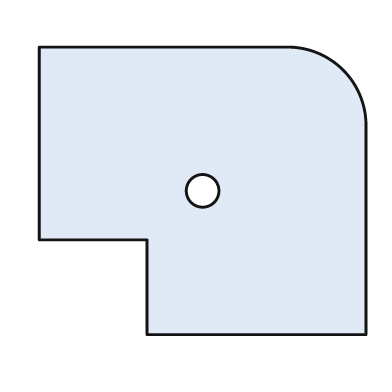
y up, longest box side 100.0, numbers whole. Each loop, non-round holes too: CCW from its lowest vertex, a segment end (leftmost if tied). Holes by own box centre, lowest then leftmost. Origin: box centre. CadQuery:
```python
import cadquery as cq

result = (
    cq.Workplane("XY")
    .moveTo(-17.0, -44.0)
    .lineTo(50.0, -44.0)
    .lineTo(50.0, 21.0)
    .threePointArc((43.0, 37.0), (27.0, 44.0))
    .lineTo(-50.0, 44.0)
    .lineTo(-50.0, -15.0)
    .lineTo(-17.0, -15.0)
    .close()
    .moveTo(0.0, 0.0)
    .circle(5.0)
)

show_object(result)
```